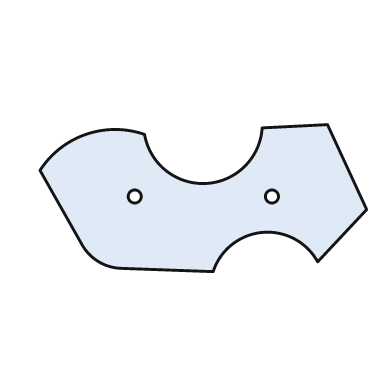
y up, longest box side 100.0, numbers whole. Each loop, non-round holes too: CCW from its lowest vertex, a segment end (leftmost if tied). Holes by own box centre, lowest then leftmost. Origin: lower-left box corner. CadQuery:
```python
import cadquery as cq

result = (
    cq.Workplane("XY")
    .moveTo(53.0, 0.0)
    .threePointArc((68.0, 12.0), (85.0, 3.0))
    .lineTo(100.0, 19.0)
    .lineTo(88.0, 45.0)
    .lineTo(68.0, 44.0)
    .threePointArc((51.0, 27.0), (32.0, 42.0))
    .threePointArc((14.0, 42.0), (0.0, 31.0))
    .lineTo(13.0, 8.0)
    .threePointArc((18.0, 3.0), (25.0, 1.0))
    .close()
    .moveTo(29.0, 23.0)
    .circle(2.0)
    .moveTo(71.0, 23.0)
    .circle(2.0)
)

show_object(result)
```